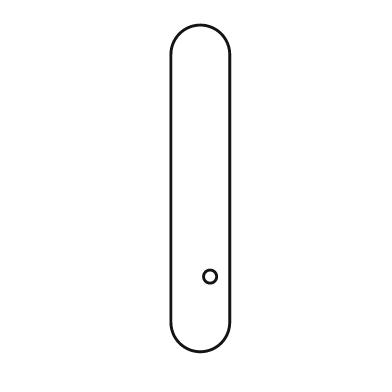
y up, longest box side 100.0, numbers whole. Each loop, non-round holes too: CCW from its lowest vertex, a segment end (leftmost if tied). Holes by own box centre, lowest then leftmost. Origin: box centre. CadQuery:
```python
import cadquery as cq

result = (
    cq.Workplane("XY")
    .moveTo(-9.0, -41.0)
    .threePointArc((0.0, -50.0), (9.0, -41.0))
    .lineTo(9.0, 41.0)
    .threePointArc((0.0, 50.0), (-9.0, 41.0))
    .close()
    .moveTo(3.0, -27.0)
    .circle(2.0)
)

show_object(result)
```